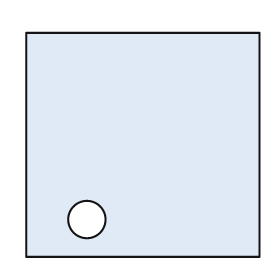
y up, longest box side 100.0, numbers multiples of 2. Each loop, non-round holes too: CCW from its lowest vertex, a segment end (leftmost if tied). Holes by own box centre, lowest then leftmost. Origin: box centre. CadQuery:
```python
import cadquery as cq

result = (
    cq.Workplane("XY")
    .moveTo(-50.0, -48.0)
    .lineTo(50.0, -48.0)
    .lineTo(50.0, 48.0)
    .lineTo(-50.0, 48.0)
    .close()
    .moveTo(-24.0, -32.0)
    .circle(8.0)
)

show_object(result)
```